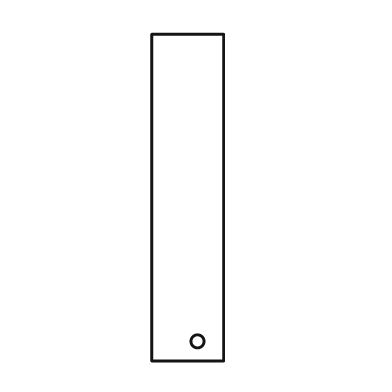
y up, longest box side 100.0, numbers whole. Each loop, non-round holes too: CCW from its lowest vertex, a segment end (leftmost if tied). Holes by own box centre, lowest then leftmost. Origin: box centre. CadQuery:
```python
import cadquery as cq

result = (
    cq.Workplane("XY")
    .moveTo(-11.0, -50.0)
    .lineTo(11.0, -50.0)
    .lineTo(11.0, 50.0)
    .lineTo(-11.0, 50.0)
    .close()
    .moveTo(3.0, -44.0)
    .circle(2.0)
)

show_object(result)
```